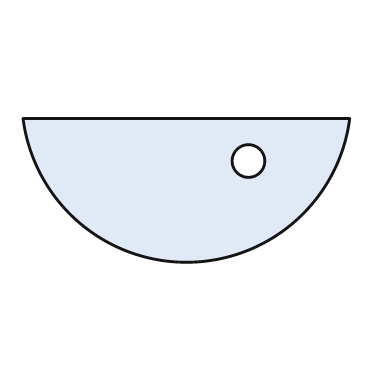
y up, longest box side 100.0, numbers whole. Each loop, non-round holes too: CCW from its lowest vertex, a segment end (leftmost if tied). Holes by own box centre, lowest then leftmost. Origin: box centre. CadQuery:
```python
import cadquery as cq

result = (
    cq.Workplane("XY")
    .moveTo(-50.0, 22.0)
    .threePointArc((0.0, -22.0), (50.0, 22.0))
    .close()
    .moveTo(19.0, 9.0)
    .circle(5.0)
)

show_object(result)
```